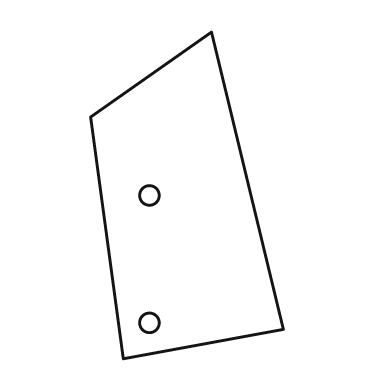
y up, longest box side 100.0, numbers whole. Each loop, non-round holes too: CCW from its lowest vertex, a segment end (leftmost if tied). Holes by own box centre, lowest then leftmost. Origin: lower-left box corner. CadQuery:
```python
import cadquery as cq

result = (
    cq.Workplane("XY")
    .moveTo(10.0, 0.0)
    .lineTo(59.0, 9.0)
    .lineTo(37.0, 100.0)
    .lineTo(0.0, 74.0)
    .close()
    .moveTo(18.0, 11.0)
    .circle(3.0)
    .moveTo(18.0, 50.0)
    .circle(3.0)
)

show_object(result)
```